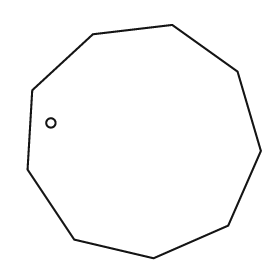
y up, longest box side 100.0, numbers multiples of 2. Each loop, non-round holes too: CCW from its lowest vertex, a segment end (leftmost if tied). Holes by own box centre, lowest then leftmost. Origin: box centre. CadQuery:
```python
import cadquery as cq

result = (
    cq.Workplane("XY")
    .moveTo(4.0, -50.0)
    .lineTo(36.0, -36.0)
    .lineTo(50.0, -4.0)
    .lineTo(40.0, 30.0)
    .lineTo(12.0, 50.0)
    .lineTo(-22.0, 46.0)
    .lineTo(-48.0, 22.0)
    .lineTo(-50.0, -12.0)
    .lineTo(-30.0, -42.0)
    .close()
    .moveTo(-40.0, 8.0)
    .circle(2.0)
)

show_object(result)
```